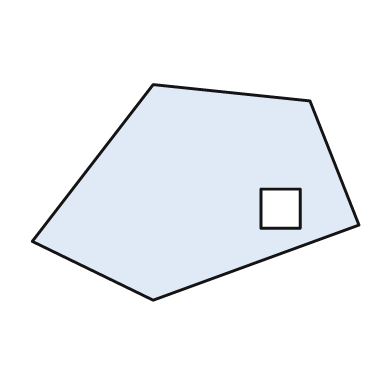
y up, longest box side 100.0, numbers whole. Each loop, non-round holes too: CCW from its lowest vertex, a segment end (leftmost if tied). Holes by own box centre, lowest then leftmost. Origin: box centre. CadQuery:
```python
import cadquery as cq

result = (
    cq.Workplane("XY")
    .moveTo(-13.0, -33.0)
    .lineTo(50.0, -10.0)
    .lineTo(35.0, 28.0)
    .lineTo(-13.0, 33.0)
    .lineTo(-50.0, -15.0)
    .close()
    .moveTo(20.0, -11.0)
    .lineTo(32.0, -11.0)
    .lineTo(32.0, 1.0)
    .lineTo(20.0, 1.0)
    .close()
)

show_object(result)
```